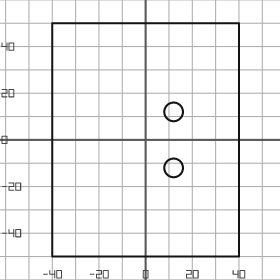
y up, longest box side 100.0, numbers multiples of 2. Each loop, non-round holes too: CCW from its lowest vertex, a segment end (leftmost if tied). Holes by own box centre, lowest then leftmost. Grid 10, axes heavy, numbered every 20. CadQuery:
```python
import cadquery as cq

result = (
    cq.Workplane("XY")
    .moveTo(-40.0, -50.0)
    .lineTo(40.0, -50.0)
    .lineTo(40.0, 50.0)
    .lineTo(-40.0, 50.0)
    .close()
    .moveTo(12.0, -12.0)
    .circle(4.0)
    .moveTo(12.0, 12.0)
    .circle(4.0)
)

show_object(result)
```